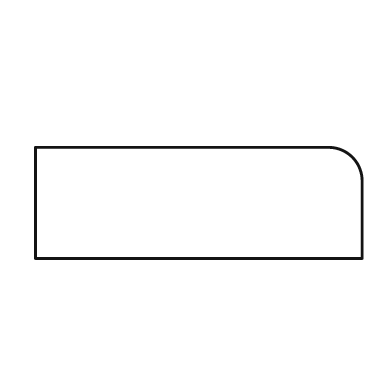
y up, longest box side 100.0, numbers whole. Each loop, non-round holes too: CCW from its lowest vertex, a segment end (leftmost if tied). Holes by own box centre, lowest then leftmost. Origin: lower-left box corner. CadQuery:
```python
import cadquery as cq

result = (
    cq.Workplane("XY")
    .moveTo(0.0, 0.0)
    .lineTo(100.0, 0.0)
    .lineTo(100.0, 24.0)
    .threePointArc((97.0, 31.0), (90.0, 34.0))
    .lineTo(0.0, 34.0)
    .close()
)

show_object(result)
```